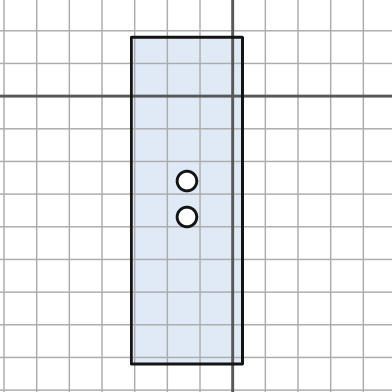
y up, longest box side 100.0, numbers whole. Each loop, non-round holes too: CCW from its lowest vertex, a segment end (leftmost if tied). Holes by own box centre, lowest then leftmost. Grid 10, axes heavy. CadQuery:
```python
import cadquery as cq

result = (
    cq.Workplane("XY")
    .moveTo(-31.0, -82.0)
    .lineTo(3.0, -82.0)
    .lineTo(3.0, 18.0)
    .lineTo(-31.0, 18.0)
    .close()
    .moveTo(-14.0, -37.0)
    .circle(3.0)
    .moveTo(-14.0, -26.0)
    .circle(3.0)
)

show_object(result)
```